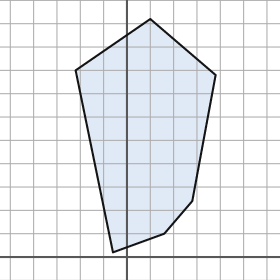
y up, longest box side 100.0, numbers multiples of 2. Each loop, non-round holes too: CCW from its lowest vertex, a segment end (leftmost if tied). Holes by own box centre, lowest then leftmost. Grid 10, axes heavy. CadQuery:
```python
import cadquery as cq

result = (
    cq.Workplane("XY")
    .moveTo(-6.0, 2.0)
    .lineTo(16.0, 10.0)
    .lineTo(28.0, 24.0)
    .lineTo(38.0, 78.0)
    .lineTo(10.0, 102.0)
    .lineTo(-22.0, 80.0)
    .close()
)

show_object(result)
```